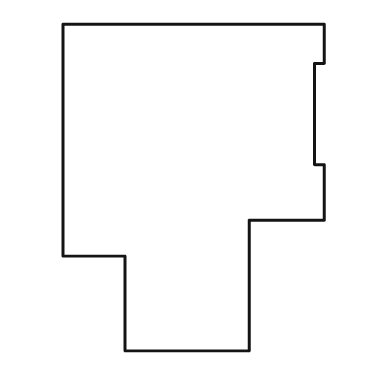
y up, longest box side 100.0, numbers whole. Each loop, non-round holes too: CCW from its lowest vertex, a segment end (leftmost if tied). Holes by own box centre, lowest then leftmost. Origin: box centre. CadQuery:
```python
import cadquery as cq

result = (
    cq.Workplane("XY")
    .moveTo(-21.0, -50.0)
    .lineTo(17.0, -50.0)
    .lineTo(17.0, -10.0)
    .lineTo(40.0, -10.0)
    .lineTo(40.0, 7.0)
    .lineTo(37.0, 7.0)
    .lineTo(37.0, 38.0)
    .lineTo(40.0, 38.0)
    .lineTo(40.0, 50.0)
    .lineTo(-40.0, 50.0)
    .lineTo(-40.0, -21.0)
    .lineTo(-21.0, -21.0)
    .close()
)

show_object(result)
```